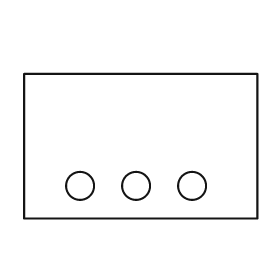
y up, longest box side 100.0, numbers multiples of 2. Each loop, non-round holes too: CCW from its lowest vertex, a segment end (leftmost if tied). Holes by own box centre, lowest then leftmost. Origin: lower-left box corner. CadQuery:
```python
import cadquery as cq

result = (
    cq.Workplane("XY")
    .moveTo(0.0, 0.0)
    .lineTo(100.0, 0.0)
    .lineTo(100.0, 62.0)
    .lineTo(0.0, 62.0)
    .close()
    .moveTo(24.0, 14.0)
    .circle(6.0)
    .moveTo(48.0, 14.0)
    .circle(6.0)
    .moveTo(72.0, 14.0)
    .circle(6.0)
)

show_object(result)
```